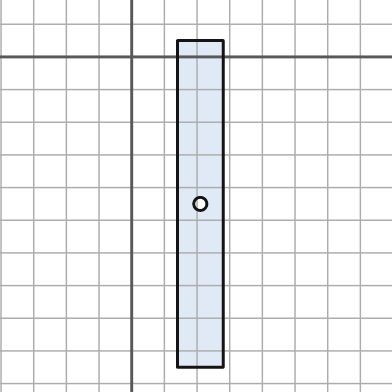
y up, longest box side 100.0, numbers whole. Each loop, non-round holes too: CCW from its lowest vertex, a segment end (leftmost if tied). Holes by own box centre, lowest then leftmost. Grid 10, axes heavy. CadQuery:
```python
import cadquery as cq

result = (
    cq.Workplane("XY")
    .moveTo(14.0, -95.0)
    .lineTo(28.0, -95.0)
    .lineTo(28.0, 5.0)
    .lineTo(14.0, 5.0)
    .close()
    .moveTo(21.0, -45.0)
    .circle(2.0)
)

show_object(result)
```